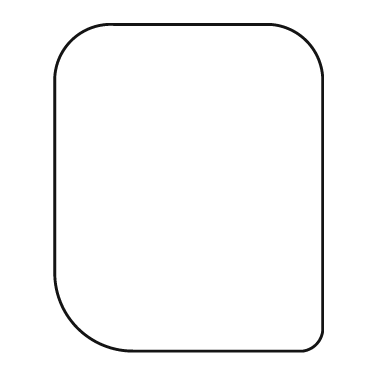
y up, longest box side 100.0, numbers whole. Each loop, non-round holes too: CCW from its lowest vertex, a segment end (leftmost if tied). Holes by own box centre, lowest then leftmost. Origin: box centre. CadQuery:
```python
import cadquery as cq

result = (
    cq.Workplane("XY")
    .moveTo(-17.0, -50.0)
    .lineTo(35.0, -50.0)
    .threePointArc((39.0, -48.0), (41.0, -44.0))
    .lineTo(41.0, 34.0)
    .threePointArc((36.0, 45.0), (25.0, 50.0))
    .lineTo(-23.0, 50.0)
    .threePointArc((-36.0, 45.0), (-41.0, 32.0))
    .lineTo(-41.0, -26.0)
    .threePointArc((-34.0, -43.0), (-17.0, -50.0))
    .close()
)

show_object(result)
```